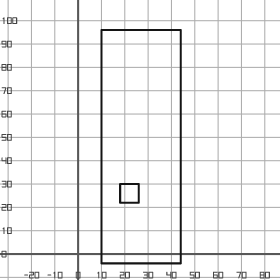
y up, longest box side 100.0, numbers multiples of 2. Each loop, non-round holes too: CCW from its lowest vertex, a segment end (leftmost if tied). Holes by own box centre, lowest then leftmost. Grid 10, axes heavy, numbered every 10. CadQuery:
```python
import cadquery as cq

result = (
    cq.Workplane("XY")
    .moveTo(10.0, -4.0)
    .lineTo(44.0, -4.0)
    .lineTo(44.0, 96.0)
    .lineTo(10.0, 96.0)
    .close()
    .moveTo(18.0, 22.0)
    .lineTo(26.0, 22.0)
    .lineTo(26.0, 30.0)
    .lineTo(18.0, 30.0)
    .close()
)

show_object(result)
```